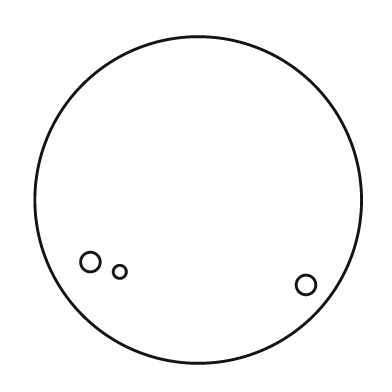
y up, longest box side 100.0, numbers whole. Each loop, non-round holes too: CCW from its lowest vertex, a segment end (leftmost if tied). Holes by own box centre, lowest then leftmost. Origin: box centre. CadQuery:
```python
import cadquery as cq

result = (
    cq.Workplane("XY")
    .moveTo(0.0, 0.0)
    .circle(50.0)
    .moveTo(33.0, -26.0)
    .circle(3.0)
    .moveTo(-24.0, -22.0)
    .circle(2.0)
    .moveTo(-33.0, -19.0)
    .circle(3.0)
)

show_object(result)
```